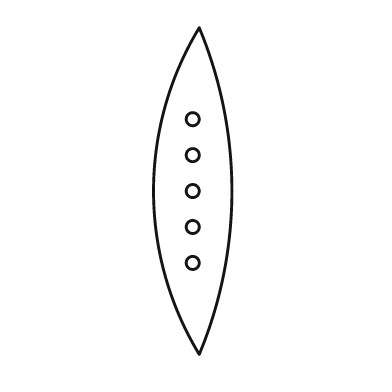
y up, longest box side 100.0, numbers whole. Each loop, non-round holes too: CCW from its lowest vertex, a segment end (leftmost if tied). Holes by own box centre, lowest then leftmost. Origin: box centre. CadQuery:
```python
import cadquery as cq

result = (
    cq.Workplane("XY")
    .moveTo(2.0, -50.0)
    .threePointArc((12.0, 0.0), (2.0, 50.0))
    .threePointArc((-12.0, 0.0), (2.0, -50.0))
    .close()
    .moveTo(0.0, -22.0)
    .circle(2.0)
    .moveTo(0.0, -11.0)
    .circle(2.0)
    .moveTo(0.0, 0.0)
    .circle(2.0)
    .moveTo(0.0, 11.0)
    .circle(2.0)
    .moveTo(0.0, 22.0)
    .circle(2.0)
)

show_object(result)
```